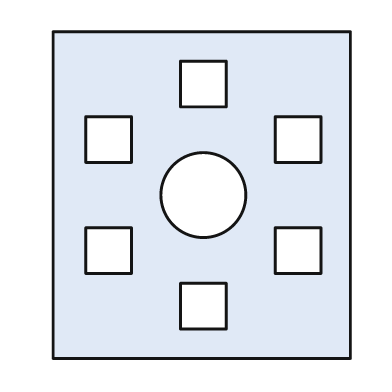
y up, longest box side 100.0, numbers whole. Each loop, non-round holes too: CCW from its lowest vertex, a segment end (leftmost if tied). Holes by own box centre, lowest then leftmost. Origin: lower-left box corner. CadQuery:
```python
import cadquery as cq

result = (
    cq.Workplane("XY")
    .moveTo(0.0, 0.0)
    .lineTo(91.0, 0.0)
    .lineTo(91.0, 100.0)
    .lineTo(0.0, 100.0)
    .close()
    .moveTo(39.0, 9.0)
    .lineTo(53.0, 9.0)
    .lineTo(53.0, 23.0)
    .lineTo(39.0, 23.0)
    .close()
    .moveTo(10.0, 26.0)
    .lineTo(24.0, 26.0)
    .lineTo(24.0, 40.0)
    .lineTo(10.0, 40.0)
    .close()
    .moveTo(68.0, 26.0)
    .lineTo(82.0, 26.0)
    .lineTo(82.0, 40.0)
    .lineTo(68.0, 40.0)
    .close()
    .moveTo(46.0, 50.0)
    .circle(13.0)
    .moveTo(10.0, 60.0)
    .lineTo(24.0, 60.0)
    .lineTo(24.0, 74.0)
    .lineTo(10.0, 74.0)
    .close()
    .moveTo(68.0, 60.0)
    .lineTo(82.0, 60.0)
    .lineTo(82.0, 74.0)
    .lineTo(68.0, 74.0)
    .close()
    .moveTo(39.0, 77.0)
    .lineTo(53.0, 77.0)
    .lineTo(53.0, 91.0)
    .lineTo(39.0, 91.0)
    .close()
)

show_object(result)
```